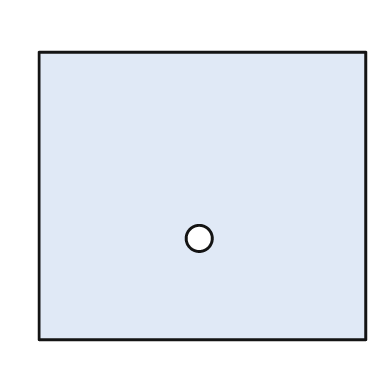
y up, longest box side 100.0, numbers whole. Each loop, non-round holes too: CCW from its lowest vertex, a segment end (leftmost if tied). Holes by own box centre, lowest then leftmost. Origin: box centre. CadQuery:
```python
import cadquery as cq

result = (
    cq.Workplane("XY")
    .moveTo(-50.0, -44.0)
    .lineTo(50.0, -44.0)
    .lineTo(50.0, 44.0)
    .lineTo(-50.0, 44.0)
    .close()
    .moveTo(-1.0, -13.0)
    .circle(4.0)
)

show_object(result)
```